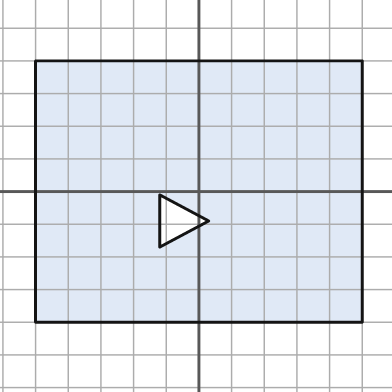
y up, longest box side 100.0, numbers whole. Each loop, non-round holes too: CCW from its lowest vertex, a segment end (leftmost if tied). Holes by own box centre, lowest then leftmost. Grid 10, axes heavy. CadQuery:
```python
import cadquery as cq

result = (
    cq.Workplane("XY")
    .moveTo(-50.0, -40.0)
    .lineTo(50.0, -40.0)
    .lineTo(50.0, 40.0)
    .lineTo(-50.0, 40.0)
    .close()
    .moveTo(-12.0, -17.0)
    .lineTo(3.0, -9.0)
    .lineTo(-12.0, -1.0)
    .close()
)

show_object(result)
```